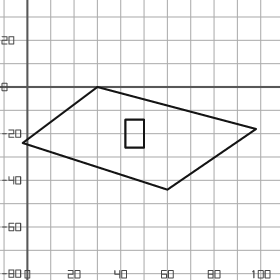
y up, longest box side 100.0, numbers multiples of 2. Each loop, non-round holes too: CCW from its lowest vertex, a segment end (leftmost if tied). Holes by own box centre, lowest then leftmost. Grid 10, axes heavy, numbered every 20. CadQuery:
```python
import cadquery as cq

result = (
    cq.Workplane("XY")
    .moveTo(60.0, -44.0)
    .lineTo(98.0, -18.0)
    .lineTo(30.0, 0.0)
    .lineTo(-2.0, -24.0)
    .close()
    .moveTo(42.0, -26.0)
    .lineTo(50.0, -26.0)
    .lineTo(50.0, -14.0)
    .lineTo(42.0, -14.0)
    .close()
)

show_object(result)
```